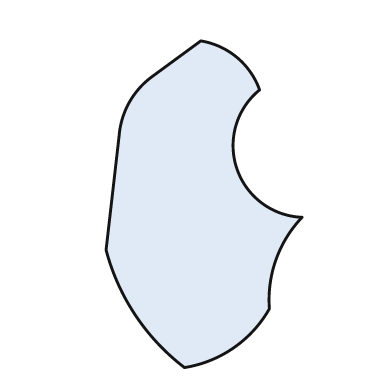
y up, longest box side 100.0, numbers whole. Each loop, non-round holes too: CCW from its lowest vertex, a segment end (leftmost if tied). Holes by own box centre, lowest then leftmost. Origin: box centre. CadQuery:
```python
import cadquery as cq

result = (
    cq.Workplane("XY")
    .moveTo(-6.0, -50.0)
    .threePointArc((9.0, -44.0), (20.0, -32.0))
    .threePointArc((22.0, -17.0), (30.0, -4.0))
    .threePointArc((10.0, 11.0), (17.0, 35.0))
    .threePointArc((10.0, 45.0), (-1.0, 50.0))
    .lineTo(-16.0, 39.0)
    .threePointArc((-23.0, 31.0), (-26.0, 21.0))
    .lineTo(-30.0, -14.0)
    .threePointArc((-21.0, -34.0), (-6.0, -50.0))
    .close()
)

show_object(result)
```